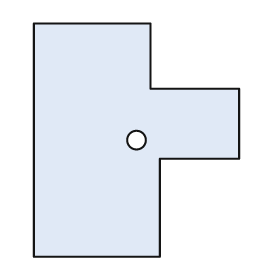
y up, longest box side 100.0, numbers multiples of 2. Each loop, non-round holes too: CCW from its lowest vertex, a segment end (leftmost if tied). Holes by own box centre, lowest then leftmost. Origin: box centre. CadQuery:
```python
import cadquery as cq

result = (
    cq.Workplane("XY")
    .moveTo(-44.0, -50.0)
    .lineTo(10.0, -50.0)
    .lineTo(10.0, -8.0)
    .lineTo(44.0, -8.0)
    .lineTo(44.0, 22.0)
    .lineTo(6.0, 22.0)
    .lineTo(6.0, 50.0)
    .lineTo(-44.0, 50.0)
    .close()
    .moveTo(0.0, 0.0)
    .circle(4.0)
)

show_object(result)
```